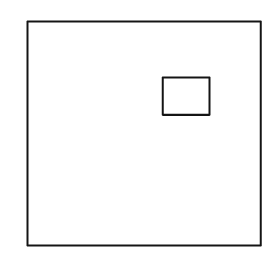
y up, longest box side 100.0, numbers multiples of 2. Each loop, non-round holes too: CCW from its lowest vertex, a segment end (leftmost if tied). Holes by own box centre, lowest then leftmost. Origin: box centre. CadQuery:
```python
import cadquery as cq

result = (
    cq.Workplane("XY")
    .moveTo(-50.0, -48.0)
    .lineTo(50.0, -48.0)
    .lineTo(50.0, 48.0)
    .lineTo(-50.0, 48.0)
    .close()
    .moveTo(8.0, 8.0)
    .lineTo(28.0, 8.0)
    .lineTo(28.0, 24.0)
    .lineTo(8.0, 24.0)
    .close()
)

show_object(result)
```